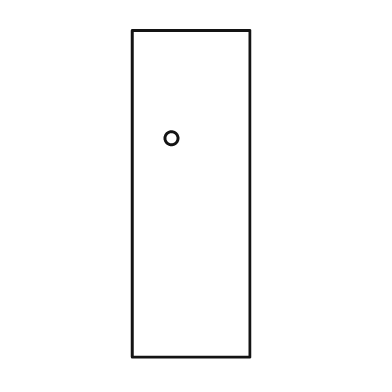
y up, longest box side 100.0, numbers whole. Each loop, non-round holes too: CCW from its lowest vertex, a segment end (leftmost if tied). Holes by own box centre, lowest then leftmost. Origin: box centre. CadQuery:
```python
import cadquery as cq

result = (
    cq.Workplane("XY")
    .moveTo(-18.0, -50.0)
    .lineTo(18.0, -50.0)
    .lineTo(18.0, 50.0)
    .lineTo(-18.0, 50.0)
    .close()
    .moveTo(-6.0, 17.0)
    .circle(2.0)
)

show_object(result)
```